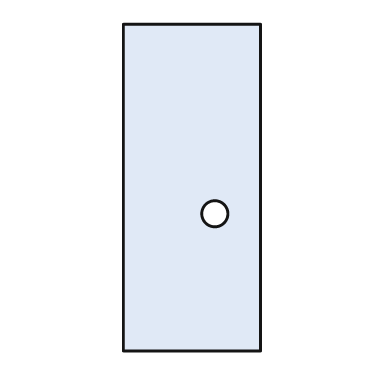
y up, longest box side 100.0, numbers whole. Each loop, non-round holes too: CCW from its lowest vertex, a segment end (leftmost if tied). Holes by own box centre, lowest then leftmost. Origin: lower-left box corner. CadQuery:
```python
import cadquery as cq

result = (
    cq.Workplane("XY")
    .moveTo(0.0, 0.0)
    .lineTo(42.0, 0.0)
    .lineTo(42.0, 100.0)
    .lineTo(0.0, 100.0)
    .close()
    .moveTo(28.0, 42.0)
    .circle(4.0)
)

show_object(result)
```